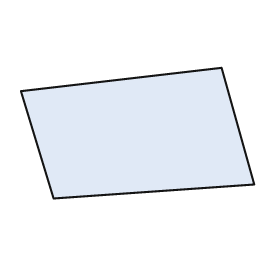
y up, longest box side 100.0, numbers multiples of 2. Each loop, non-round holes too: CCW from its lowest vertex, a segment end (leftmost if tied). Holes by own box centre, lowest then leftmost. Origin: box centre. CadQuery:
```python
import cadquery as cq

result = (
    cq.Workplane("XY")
    .moveTo(-36.0, -28.0)
    .lineTo(50.0, -22.0)
    .lineTo(36.0, 28.0)
    .lineTo(-50.0, 18.0)
    .close()
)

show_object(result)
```